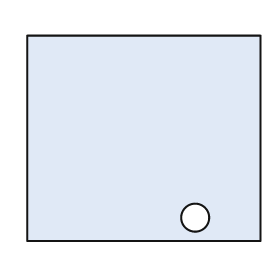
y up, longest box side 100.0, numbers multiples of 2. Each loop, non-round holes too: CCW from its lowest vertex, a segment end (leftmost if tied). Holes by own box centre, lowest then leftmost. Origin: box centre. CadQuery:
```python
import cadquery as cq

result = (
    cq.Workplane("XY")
    .moveTo(-50.0, -44.0)
    .lineTo(50.0, -44.0)
    .lineTo(50.0, 44.0)
    .lineTo(-50.0, 44.0)
    .close()
    .moveTo(22.0, -34.0)
    .circle(6.0)
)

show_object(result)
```